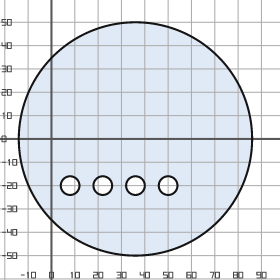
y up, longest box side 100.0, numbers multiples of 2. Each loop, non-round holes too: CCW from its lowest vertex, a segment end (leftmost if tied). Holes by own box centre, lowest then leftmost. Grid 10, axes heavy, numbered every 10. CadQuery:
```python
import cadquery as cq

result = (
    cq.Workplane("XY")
    .moveTo(36.0, 0.0)
    .circle(50.0)
    .moveTo(8.0, -20.0)
    .circle(4.0)
    .moveTo(22.0, -20.0)
    .circle(4.0)
    .moveTo(36.0, -20.0)
    .circle(4.0)
    .moveTo(50.0, -20.0)
    .circle(4.0)
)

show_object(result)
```